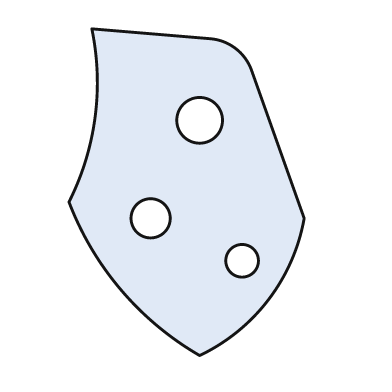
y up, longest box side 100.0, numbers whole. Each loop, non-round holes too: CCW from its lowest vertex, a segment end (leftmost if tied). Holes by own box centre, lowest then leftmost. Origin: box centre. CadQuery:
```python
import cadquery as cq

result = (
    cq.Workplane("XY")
    .moveTo(4.0, -50.0)
    .threePointArc((25.0, -33.0), (36.0, -8.0))
    .lineTo(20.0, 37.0)
    .threePointArc((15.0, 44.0), (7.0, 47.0))
    .lineTo(-29.0, 50.0)
    .threePointArc((-28.0, 23.0), (-36.0, -3.0))
    .threePointArc((-20.0, -30.0), (4.0, -50.0))
    .close()
    .moveTo(17.0, -21.0)
    .circle(5.0)
    .moveTo(-11.0, -8.0)
    .circle(6.0)
    .moveTo(4.0, 22.0)
    .circle(7.0)
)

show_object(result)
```